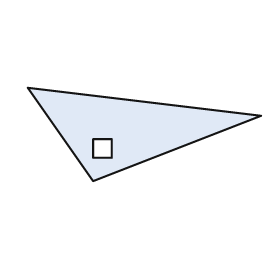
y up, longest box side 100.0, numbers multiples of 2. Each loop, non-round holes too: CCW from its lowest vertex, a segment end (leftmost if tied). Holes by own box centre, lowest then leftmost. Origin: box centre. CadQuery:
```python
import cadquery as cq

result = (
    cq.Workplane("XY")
    .moveTo(-22.0, -20.0)
    .lineTo(50.0, 8.0)
    .lineTo(-50.0, 20.0)
    .close()
    .moveTo(-22.0, -10.0)
    .lineTo(-14.0, -10.0)
    .lineTo(-14.0, -2.0)
    .lineTo(-22.0, -2.0)
    .close()
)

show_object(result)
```